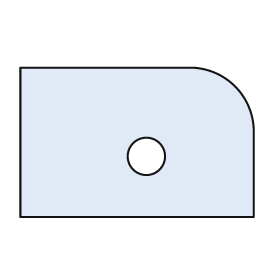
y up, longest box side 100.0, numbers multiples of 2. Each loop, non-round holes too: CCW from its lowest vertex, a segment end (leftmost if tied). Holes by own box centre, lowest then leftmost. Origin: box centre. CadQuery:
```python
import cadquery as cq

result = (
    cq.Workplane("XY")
    .moveTo(-50.0, -32.0)
    .lineTo(50.0, -32.0)
    .lineTo(50.0, 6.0)
    .threePointArc((42.0, 24.0), (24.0, 32.0))
    .lineTo(-50.0, 32.0)
    .close()
    .moveTo(4.0, -6.0)
    .circle(8.0)
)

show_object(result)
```